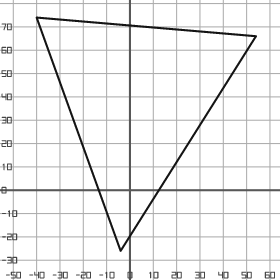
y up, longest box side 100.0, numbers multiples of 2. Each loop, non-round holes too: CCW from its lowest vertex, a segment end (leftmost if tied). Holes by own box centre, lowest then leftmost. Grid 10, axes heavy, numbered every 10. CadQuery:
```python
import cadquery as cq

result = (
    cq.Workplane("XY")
    .moveTo(-4.0, -26.0)
    .lineTo(54.0, 66.0)
    .lineTo(-40.0, 74.0)
    .close()
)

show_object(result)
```